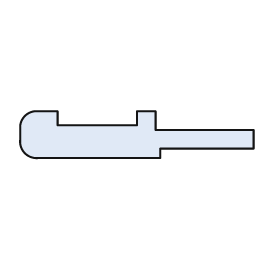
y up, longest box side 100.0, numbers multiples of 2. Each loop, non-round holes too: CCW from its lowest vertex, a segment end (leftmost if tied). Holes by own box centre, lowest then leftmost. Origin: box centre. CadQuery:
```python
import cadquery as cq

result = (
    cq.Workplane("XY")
    .moveTo(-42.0, -10.0)
    .lineTo(10.0, -10.0)
    .lineTo(10.0, -6.0)
    .lineTo(50.0, -6.0)
    .lineTo(50.0, 2.0)
    .lineTo(8.0, 2.0)
    .lineTo(8.0, 10.0)
    .lineTo(0.0, 10.0)
    .lineTo(0.0, 4.0)
    .lineTo(-34.0, 4.0)
    .lineTo(-34.0, 10.0)
    .lineTo(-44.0, 10.0)
    .threePointArc((-48.0, 8.0), (-50.0, 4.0))
    .lineTo(-50.0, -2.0)
    .threePointArc((-48.0, -8.0), (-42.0, -10.0))
    .close()
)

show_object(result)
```